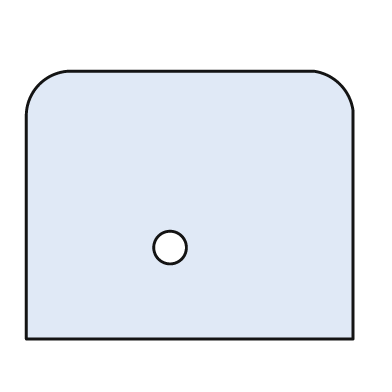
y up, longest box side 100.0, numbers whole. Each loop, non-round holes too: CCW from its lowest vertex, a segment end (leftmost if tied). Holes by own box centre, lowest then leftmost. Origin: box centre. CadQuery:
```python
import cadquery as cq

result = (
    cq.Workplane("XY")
    .moveTo(-50.0, -41.0)
    .lineTo(50.0, -41.0)
    .lineTo(50.0, 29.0)
    .threePointArc((46.0, 37.0), (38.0, 41.0))
    .lineTo(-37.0, 41.0)
    .threePointArc((-46.0, 37.0), (-50.0, 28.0))
    .close()
    .moveTo(-6.0, -13.0)
    .circle(5.0)
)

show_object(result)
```